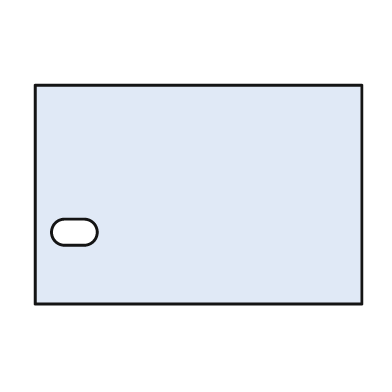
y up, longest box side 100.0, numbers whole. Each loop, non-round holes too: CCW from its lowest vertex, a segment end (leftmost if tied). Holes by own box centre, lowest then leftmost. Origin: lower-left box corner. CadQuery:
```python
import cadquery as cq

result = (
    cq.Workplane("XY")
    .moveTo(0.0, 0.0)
    .lineTo(100.0, 0.0)
    .lineTo(100.0, 67.0)
    .lineTo(0.0, 67.0)
    .close()
    .moveTo(9.0, 18.0)
    .lineTo(15.0, 18.0)
    .threePointArc((19.0, 22.0), (15.0, 26.0))
    .lineTo(9.0, 26.0)
    .threePointArc((5.0, 22.0), (9.0, 18.0))
    .close()
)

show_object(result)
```